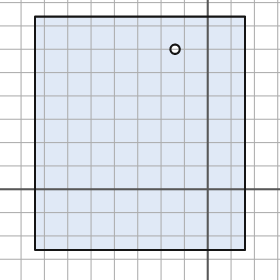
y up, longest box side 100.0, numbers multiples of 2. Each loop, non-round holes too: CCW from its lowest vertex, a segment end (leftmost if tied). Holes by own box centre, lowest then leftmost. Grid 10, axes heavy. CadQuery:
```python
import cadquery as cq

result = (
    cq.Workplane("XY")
    .moveTo(-74.0, -26.0)
    .lineTo(16.0, -26.0)
    .lineTo(16.0, 74.0)
    .lineTo(-74.0, 74.0)
    .close()
    .moveTo(-14.0, 60.0)
    .circle(2.0)
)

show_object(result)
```